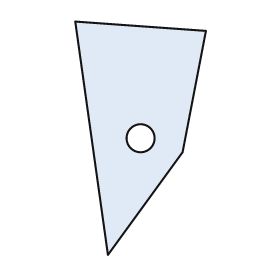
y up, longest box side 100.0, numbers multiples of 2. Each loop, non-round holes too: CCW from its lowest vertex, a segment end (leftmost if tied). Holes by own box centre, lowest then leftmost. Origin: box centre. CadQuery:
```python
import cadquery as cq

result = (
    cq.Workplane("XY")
    .moveTo(-14.0, -50.0)
    .lineTo(18.0, -6.0)
    .lineTo(28.0, 46.0)
    .lineTo(-28.0, 50.0)
    .close()
    .moveTo(0.0, 0.0)
    .circle(6.0)
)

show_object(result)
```